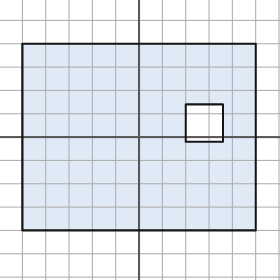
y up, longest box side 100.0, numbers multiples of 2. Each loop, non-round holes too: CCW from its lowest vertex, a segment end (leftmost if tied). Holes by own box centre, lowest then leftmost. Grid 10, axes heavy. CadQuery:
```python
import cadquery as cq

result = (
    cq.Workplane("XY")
    .moveTo(-50.0, -40.0)
    .lineTo(50.0, -40.0)
    .lineTo(50.0, 40.0)
    .lineTo(-50.0, 40.0)
    .close()
    .moveTo(20.0, -2.0)
    .lineTo(36.0, -2.0)
    .lineTo(36.0, 14.0)
    .lineTo(20.0, 14.0)
    .close()
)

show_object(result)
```